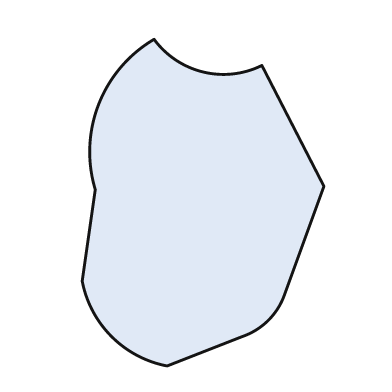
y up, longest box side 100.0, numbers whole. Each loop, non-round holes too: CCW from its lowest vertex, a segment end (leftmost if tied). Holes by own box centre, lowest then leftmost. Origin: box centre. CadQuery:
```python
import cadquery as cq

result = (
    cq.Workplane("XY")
    .moveTo(-11.0, -50.0)
    .lineTo(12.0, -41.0)
    .threePointArc((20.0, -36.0), (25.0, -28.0))
    .lineTo(37.0, 5.0)
    .lineTo(18.0, 42.0)
    .threePointArc((0.0, 40.0), (-15.0, 50.0))
    .threePointArc((-32.0, 30.0), (-33.0, 4.0))
    .lineTo(-37.0, -24.0)
    .threePointArc((-28.0, -41.0), (-11.0, -50.0))
    .close()
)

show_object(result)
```